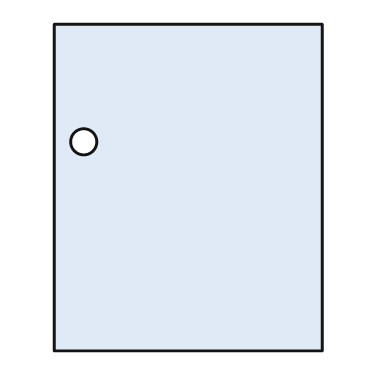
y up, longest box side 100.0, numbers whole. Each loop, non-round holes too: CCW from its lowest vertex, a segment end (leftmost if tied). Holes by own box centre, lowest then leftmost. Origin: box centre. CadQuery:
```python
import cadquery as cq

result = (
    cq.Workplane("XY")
    .moveTo(-41.0, -50.0)
    .lineTo(41.0, -50.0)
    .lineTo(41.0, 50.0)
    .lineTo(-41.0, 50.0)
    .close()
    .moveTo(-32.0, 14.0)
    .circle(4.0)
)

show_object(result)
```